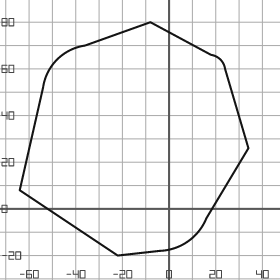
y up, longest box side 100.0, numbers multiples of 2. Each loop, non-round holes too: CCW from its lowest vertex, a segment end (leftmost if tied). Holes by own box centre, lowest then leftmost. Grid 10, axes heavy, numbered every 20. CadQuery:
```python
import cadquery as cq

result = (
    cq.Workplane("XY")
    .moveTo(-22.0, -20.0)
    .lineTo(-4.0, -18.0)
    .threePointArc((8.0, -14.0), (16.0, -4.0))
    .lineTo(34.0, 26.0)
    .lineTo(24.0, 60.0)
    .threePointArc((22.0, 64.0), (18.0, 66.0))
    .lineTo(-8.0, 80.0)
    .lineTo(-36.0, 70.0)
    .threePointArc((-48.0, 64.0), (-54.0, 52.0))
    .lineTo(-64.0, 8.0)
    .close()
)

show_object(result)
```